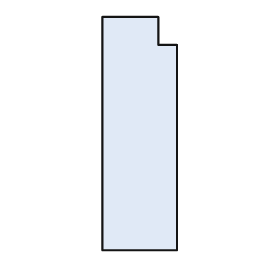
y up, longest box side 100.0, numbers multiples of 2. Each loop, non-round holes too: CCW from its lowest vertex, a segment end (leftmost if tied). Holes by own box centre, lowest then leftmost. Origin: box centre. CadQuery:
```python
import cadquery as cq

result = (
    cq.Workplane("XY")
    .moveTo(-16.0, -50.0)
    .lineTo(16.0, -50.0)
    .lineTo(16.0, 38.0)
    .lineTo(8.0, 38.0)
    .lineTo(8.0, 50.0)
    .lineTo(-16.0, 50.0)
    .close()
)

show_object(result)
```